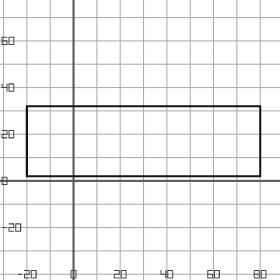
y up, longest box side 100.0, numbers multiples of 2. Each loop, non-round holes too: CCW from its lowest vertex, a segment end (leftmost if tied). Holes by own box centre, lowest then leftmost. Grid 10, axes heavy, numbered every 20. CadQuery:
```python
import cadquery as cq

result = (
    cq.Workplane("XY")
    .moveTo(-20.0, 2.0)
    .lineTo(80.0, 2.0)
    .lineTo(80.0, 32.0)
    .lineTo(-20.0, 32.0)
    .close()
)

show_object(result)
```